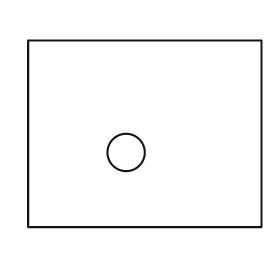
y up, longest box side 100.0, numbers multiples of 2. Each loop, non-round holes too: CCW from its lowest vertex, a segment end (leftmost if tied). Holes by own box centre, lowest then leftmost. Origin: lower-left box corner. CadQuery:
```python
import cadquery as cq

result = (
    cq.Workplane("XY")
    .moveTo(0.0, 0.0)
    .lineTo(100.0, 0.0)
    .lineTo(100.0, 80.0)
    .lineTo(0.0, 80.0)
    .close()
    .moveTo(42.0, 32.0)
    .circle(8.0)
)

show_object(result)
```